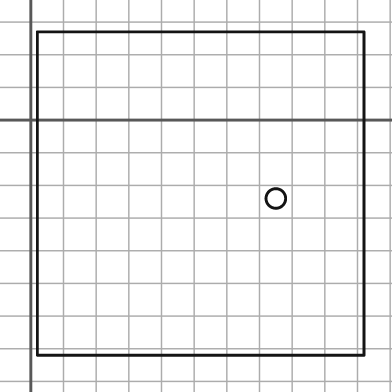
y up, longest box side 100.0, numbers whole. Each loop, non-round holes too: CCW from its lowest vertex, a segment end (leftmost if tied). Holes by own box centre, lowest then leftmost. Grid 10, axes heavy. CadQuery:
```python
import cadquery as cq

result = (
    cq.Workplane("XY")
    .moveTo(2.0, -72.0)
    .lineTo(102.0, -72.0)
    .lineTo(102.0, 27.0)
    .lineTo(2.0, 27.0)
    .close()
    .moveTo(75.0, -24.0)
    .circle(3.0)
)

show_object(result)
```